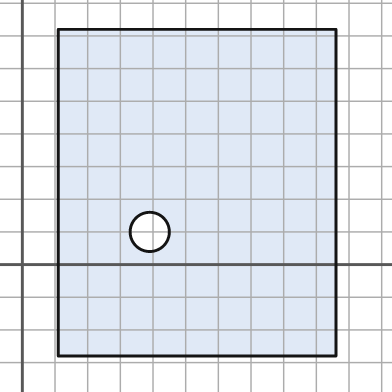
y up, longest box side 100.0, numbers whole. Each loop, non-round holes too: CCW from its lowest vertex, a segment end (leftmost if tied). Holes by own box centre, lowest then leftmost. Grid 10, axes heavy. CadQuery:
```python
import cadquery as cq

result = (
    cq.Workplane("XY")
    .moveTo(11.0, -28.0)
    .lineTo(96.0, -28.0)
    .lineTo(96.0, 72.0)
    .lineTo(11.0, 72.0)
    .close()
    .moveTo(39.0, 10.0)
    .circle(6.0)
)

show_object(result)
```